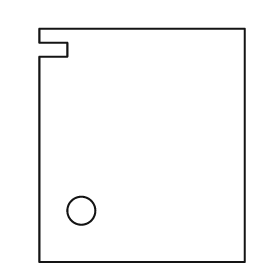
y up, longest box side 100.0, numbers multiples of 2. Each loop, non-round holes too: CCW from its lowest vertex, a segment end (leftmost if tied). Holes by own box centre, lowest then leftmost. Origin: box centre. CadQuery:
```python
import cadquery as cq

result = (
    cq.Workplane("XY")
    .moveTo(-44.0, -50.0)
    .lineTo(44.0, -50.0)
    .lineTo(44.0, 50.0)
    .lineTo(-44.0, 50.0)
    .lineTo(-44.0, 44.0)
    .lineTo(-32.0, 44.0)
    .lineTo(-32.0, 38.0)
    .lineTo(-44.0, 38.0)
    .close()
    .moveTo(-26.0, -28.0)
    .circle(6.0)
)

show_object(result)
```